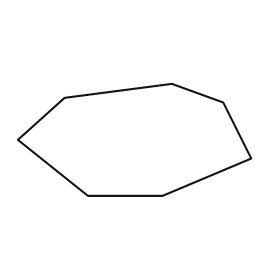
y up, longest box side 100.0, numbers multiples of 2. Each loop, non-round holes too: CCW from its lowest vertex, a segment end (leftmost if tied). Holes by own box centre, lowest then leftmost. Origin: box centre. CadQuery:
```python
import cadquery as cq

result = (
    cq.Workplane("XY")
    .moveTo(-20.0, -24.0)
    .lineTo(12.0, -24.0)
    .lineTo(50.0, -8.0)
    .lineTo(38.0, 16.0)
    .lineTo(16.0, 24.0)
    .lineTo(-30.0, 18.0)
    .lineTo(-50.0, 0.0)
    .close()
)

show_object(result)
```